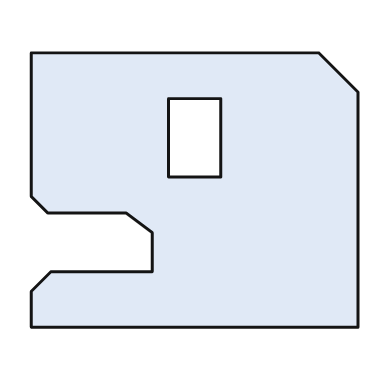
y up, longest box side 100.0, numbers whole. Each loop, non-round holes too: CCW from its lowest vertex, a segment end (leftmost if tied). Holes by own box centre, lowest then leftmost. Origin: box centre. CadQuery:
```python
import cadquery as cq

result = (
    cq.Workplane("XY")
    .moveTo(-50.0, -42.0)
    .lineTo(50.0, -42.0)
    .lineTo(50.0, 30.0)
    .lineTo(38.0, 42.0)
    .lineTo(-50.0, 42.0)
    .lineTo(-50.0, -2.0)
    .lineTo(-45.0, -7.0)
    .lineTo(-21.0, -7.0)
    .lineTo(-13.0, -13.0)
    .lineTo(-13.0, -25.0)
    .lineTo(-44.0, -25.0)
    .lineTo(-50.0, -31.0)
    .close()
    .moveTo(-8.0, 4.0)
    .lineTo(8.0, 4.0)
    .lineTo(8.0, 28.0)
    .lineTo(-8.0, 28.0)
    .close()
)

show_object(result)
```